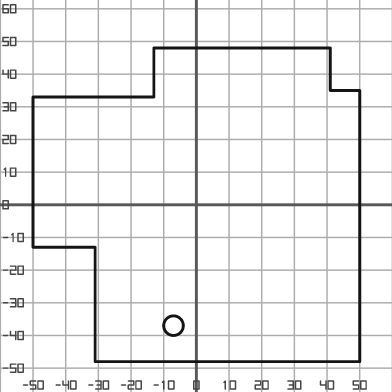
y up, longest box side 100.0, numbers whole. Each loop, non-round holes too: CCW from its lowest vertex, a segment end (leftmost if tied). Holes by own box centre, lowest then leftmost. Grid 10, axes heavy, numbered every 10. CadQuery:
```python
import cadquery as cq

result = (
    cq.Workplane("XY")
    .moveTo(-31.0, -48.0)
    .lineTo(50.0, -48.0)
    .lineTo(50.0, 35.0)
    .lineTo(41.0, 35.0)
    .lineTo(41.0, 48.0)
    .lineTo(-13.0, 48.0)
    .lineTo(-13.0, 33.0)
    .lineTo(-50.0, 33.0)
    .lineTo(-50.0, -13.0)
    .lineTo(-31.0, -13.0)
    .close()
    .moveTo(-7.0, -37.0)
    .circle(3.0)
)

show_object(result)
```